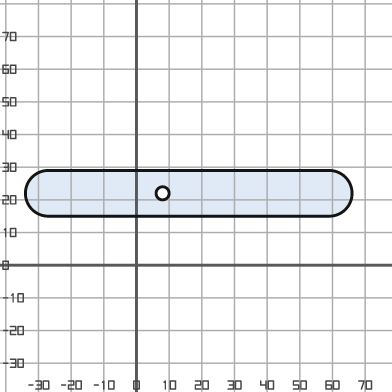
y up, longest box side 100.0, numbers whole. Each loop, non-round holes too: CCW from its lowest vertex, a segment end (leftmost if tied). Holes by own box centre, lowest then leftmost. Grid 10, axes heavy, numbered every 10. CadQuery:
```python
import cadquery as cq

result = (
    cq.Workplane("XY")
    .moveTo(-27.0, 15.0)
    .lineTo(59.0, 15.0)
    .threePointArc((66.0, 22.0), (59.0, 29.0))
    .lineTo(-27.0, 29.0)
    .threePointArc((-34.0, 22.0), (-27.0, 15.0))
    .close()
    .moveTo(8.0, 22.0)
    .circle(2.0)
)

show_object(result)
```